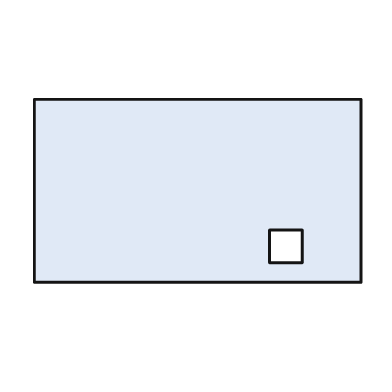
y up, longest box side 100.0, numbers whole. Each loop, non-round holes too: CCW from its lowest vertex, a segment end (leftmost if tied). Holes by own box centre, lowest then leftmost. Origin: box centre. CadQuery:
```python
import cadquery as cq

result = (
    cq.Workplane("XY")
    .moveTo(-50.0, -28.0)
    .lineTo(50.0, -28.0)
    .lineTo(50.0, 28.0)
    .lineTo(-50.0, 28.0)
    .close()
    .moveTo(22.0, -22.0)
    .lineTo(32.0, -22.0)
    .lineTo(32.0, -12.0)
    .lineTo(22.0, -12.0)
    .close()
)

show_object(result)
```